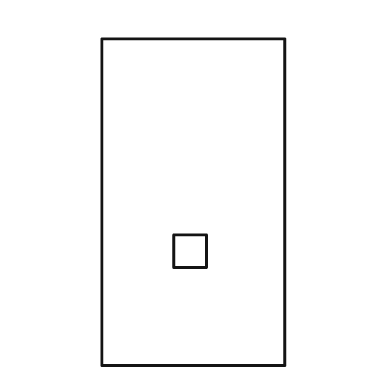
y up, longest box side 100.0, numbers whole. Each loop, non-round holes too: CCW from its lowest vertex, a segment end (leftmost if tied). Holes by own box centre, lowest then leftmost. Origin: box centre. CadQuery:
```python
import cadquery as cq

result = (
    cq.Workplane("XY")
    .moveTo(-28.0, -50.0)
    .lineTo(28.0, -50.0)
    .lineTo(28.0, 50.0)
    .lineTo(-28.0, 50.0)
    .close()
    .moveTo(-6.0, -20.0)
    .lineTo(4.0, -20.0)
    .lineTo(4.0, -10.0)
    .lineTo(-6.0, -10.0)
    .close()
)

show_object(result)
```